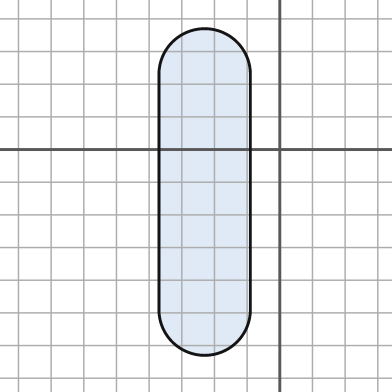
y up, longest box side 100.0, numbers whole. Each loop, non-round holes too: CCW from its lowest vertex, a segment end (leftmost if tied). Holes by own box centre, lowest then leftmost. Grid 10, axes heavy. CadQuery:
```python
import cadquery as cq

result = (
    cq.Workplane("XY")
    .moveTo(-37.0, -49.0)
    .threePointArc((-23.0, -63.0), (-9.0, -49.0))
    .lineTo(-9.0, 23.0)
    .threePointArc((-23.0, 37.0), (-37.0, 23.0))
    .close()
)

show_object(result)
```